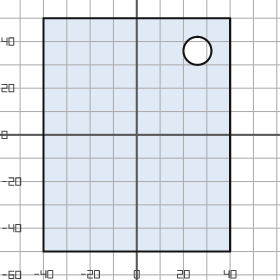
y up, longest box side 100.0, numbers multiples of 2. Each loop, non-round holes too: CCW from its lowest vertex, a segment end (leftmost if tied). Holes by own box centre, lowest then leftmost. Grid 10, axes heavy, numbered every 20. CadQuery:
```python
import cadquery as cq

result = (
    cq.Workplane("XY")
    .moveTo(-40.0, -50.0)
    .lineTo(40.0, -50.0)
    .lineTo(40.0, 50.0)
    .lineTo(-40.0, 50.0)
    .close()
    .moveTo(26.0, 36.0)
    .circle(6.0)
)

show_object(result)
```